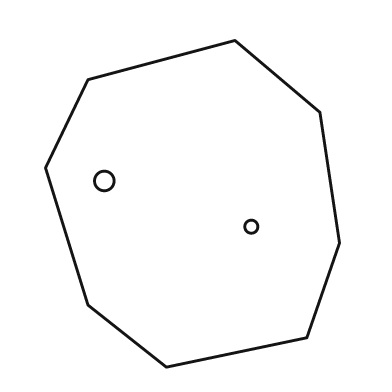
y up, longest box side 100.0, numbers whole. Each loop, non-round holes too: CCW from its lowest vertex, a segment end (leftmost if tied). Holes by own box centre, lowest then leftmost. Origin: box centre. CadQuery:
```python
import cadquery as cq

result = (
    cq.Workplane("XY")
    .moveTo(-8.0, -50.0)
    .lineTo(35.0, -41.0)
    .lineTo(45.0, -12.0)
    .lineTo(39.0, 28.0)
    .lineTo(13.0, 50.0)
    .lineTo(-32.0, 38.0)
    .lineTo(-45.0, 11.0)
    .lineTo(-32.0, -31.0)
    .close()
    .moveTo(18.0, -7.0)
    .circle(2.0)
    .moveTo(-27.0, 7.0)
    .circle(3.0)
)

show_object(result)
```